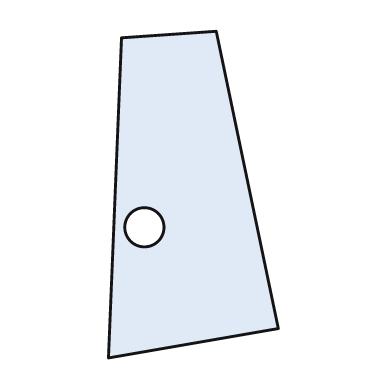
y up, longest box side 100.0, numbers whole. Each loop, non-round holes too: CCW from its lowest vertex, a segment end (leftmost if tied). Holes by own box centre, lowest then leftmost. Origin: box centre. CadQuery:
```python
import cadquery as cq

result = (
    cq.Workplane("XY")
    .moveTo(-26.0, -50.0)
    .lineTo(26.0, -41.0)
    .lineTo(7.0, 50.0)
    .lineTo(-22.0, 48.0)
    .close()
    .moveTo(-15.0, -10.0)
    .circle(6.0)
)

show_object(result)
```